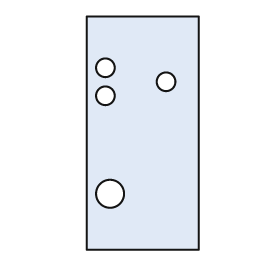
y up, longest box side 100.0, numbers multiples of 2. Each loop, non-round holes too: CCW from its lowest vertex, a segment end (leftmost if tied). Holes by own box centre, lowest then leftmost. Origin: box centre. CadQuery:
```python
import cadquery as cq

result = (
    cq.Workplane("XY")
    .moveTo(-24.0, -50.0)
    .lineTo(24.0, -50.0)
    .lineTo(24.0, 50.0)
    .lineTo(-24.0, 50.0)
    .close()
    .moveTo(-14.0, -26.0)
    .circle(6.0)
    .moveTo(-16.0, 16.0)
    .circle(4.0)
    .moveTo(10.0, 22.0)
    .circle(4.0)
    .moveTo(-16.0, 28.0)
    .circle(4.0)
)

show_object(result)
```